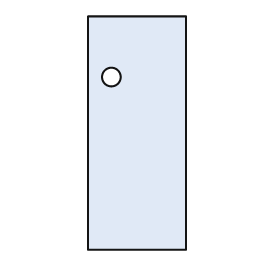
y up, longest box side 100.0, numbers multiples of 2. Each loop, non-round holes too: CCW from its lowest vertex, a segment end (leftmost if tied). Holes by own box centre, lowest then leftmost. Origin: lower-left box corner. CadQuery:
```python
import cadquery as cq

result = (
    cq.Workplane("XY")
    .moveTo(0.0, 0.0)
    .lineTo(42.0, 0.0)
    .lineTo(42.0, 100.0)
    .lineTo(0.0, 100.0)
    .close()
    .moveTo(10.0, 74.0)
    .circle(4.0)
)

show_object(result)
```